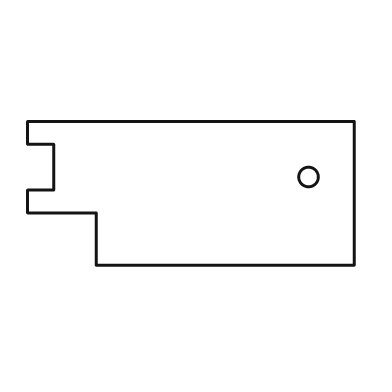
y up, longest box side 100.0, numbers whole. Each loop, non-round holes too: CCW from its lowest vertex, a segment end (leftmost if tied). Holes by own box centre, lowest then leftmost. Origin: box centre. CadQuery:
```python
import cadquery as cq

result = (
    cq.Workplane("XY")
    .moveTo(-29.0, -22.0)
    .lineTo(50.0, -22.0)
    .lineTo(50.0, 22.0)
    .lineTo(-50.0, 22.0)
    .lineTo(-50.0, 15.0)
    .lineTo(-42.0, 15.0)
    .lineTo(-42.0, 1.0)
    .lineTo(-50.0, 1.0)
    .lineTo(-50.0, -6.0)
    .lineTo(-29.0, -6.0)
    .close()
    .moveTo(36.0, 5.0)
    .circle(3.0)
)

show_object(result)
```